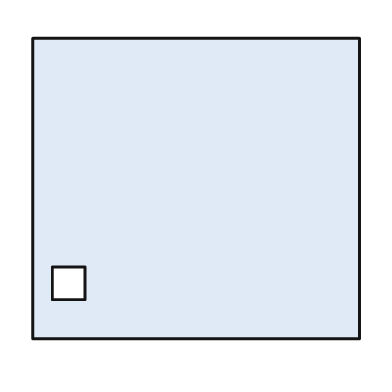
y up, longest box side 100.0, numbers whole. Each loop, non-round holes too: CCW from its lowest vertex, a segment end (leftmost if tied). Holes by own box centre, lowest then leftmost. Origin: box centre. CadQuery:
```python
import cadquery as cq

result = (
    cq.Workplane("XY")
    .moveTo(-50.0, -46.0)
    .lineTo(50.0, -46.0)
    .lineTo(50.0, 46.0)
    .lineTo(-50.0, 46.0)
    .close()
    .moveTo(-44.0, -34.0)
    .lineTo(-34.0, -34.0)
    .lineTo(-34.0, -24.0)
    .lineTo(-44.0, -24.0)
    .close()
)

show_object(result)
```